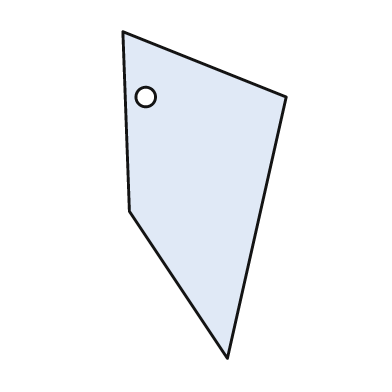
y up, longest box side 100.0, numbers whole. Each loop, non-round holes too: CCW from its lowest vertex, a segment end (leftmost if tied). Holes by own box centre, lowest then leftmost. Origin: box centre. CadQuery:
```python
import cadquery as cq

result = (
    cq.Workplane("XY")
    .moveTo(7.0, -50.0)
    .lineTo(25.0, 30.0)
    .lineTo(-25.0, 50.0)
    .lineTo(-23.0, -5.0)
    .close()
    .moveTo(-18.0, 30.0)
    .circle(3.0)
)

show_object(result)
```